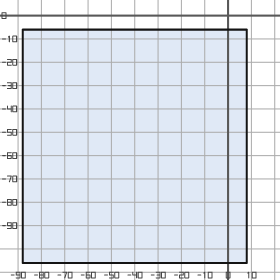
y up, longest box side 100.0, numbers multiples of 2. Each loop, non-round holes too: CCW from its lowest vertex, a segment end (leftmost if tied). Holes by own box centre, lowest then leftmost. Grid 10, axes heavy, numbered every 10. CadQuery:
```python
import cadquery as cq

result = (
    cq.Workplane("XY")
    .moveTo(-88.0, -106.0)
    .lineTo(8.0, -106.0)
    .lineTo(8.0, -6.0)
    .lineTo(-88.0, -6.0)
    .close()
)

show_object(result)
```